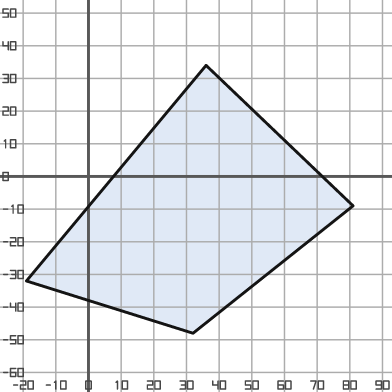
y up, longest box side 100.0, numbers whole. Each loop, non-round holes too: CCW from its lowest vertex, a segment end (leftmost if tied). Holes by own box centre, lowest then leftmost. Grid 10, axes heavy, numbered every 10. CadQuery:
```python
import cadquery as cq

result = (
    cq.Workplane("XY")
    .moveTo(32.0, -48.0)
    .lineTo(81.0, -9.0)
    .lineTo(36.0, 34.0)
    .lineTo(-19.0, -32.0)
    .close()
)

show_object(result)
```